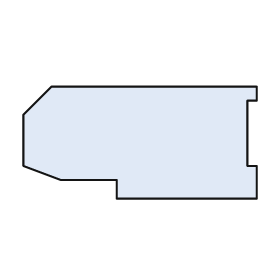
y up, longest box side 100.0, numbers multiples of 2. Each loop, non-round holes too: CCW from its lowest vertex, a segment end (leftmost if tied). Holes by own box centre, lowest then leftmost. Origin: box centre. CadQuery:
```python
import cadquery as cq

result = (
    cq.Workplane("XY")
    .moveTo(-10.0, -24.0)
    .lineTo(50.0, -24.0)
    .lineTo(50.0, -10.0)
    .lineTo(46.0, -10.0)
    .lineTo(46.0, 18.0)
    .lineTo(50.0, 18.0)
    .lineTo(50.0, 24.0)
    .lineTo(-38.0, 24.0)
    .lineTo(-50.0, 12.0)
    .lineTo(-50.0, -10.0)
    .lineTo(-34.0, -16.0)
    .lineTo(-10.0, -16.0)
    .close()
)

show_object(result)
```